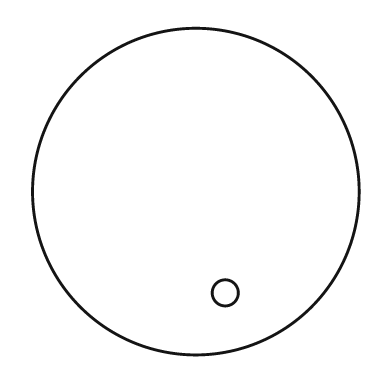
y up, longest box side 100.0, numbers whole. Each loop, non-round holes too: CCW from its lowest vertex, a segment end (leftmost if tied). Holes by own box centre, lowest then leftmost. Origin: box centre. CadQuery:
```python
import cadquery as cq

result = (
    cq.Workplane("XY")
    .moveTo(0.0, 0.0)
    .circle(50.0)
    .moveTo(9.0, -31.0)
    .circle(4.0)
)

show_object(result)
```